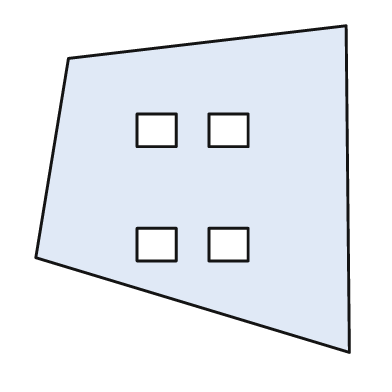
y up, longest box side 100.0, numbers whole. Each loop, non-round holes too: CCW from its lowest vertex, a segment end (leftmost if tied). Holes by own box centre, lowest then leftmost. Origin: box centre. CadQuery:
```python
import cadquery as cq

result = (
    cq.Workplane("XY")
    .moveTo(48.0, -50.0)
    .lineTo(47.0, 50.0)
    .lineTo(-38.0, 40.0)
    .lineTo(-48.0, -21.0)
    .close()
    .moveTo(-17.0, -22.0)
    .lineTo(-5.0, -22.0)
    .lineTo(-5.0, -12.0)
    .lineTo(-17.0, -12.0)
    .close()
    .moveTo(5.0, -22.0)
    .lineTo(17.0, -22.0)
    .lineTo(17.0, -12.0)
    .lineTo(5.0, -12.0)
    .close()
    .moveTo(-17.0, 13.0)
    .lineTo(-5.0, 13.0)
    .lineTo(-5.0, 23.0)
    .lineTo(-17.0, 23.0)
    .close()
    .moveTo(5.0, 13.0)
    .lineTo(17.0, 13.0)
    .lineTo(17.0, 23.0)
    .lineTo(5.0, 23.0)
    .close()
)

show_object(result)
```